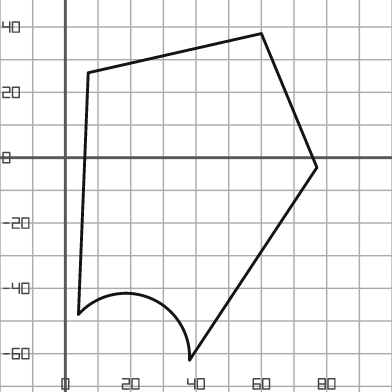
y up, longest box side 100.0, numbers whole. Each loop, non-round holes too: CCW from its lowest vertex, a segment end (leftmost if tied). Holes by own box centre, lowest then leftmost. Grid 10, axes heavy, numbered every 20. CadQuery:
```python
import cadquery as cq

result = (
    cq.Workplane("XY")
    .moveTo(38.0, -62.0)
    .lineTo(77.0, -3.0)
    .lineTo(60.0, 38.0)
    .lineTo(7.0, 26.0)
    .lineTo(4.0, -48.0)
    .threePointArc((26.0, -43.0), (38.0, -62.0))
    .close()
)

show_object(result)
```